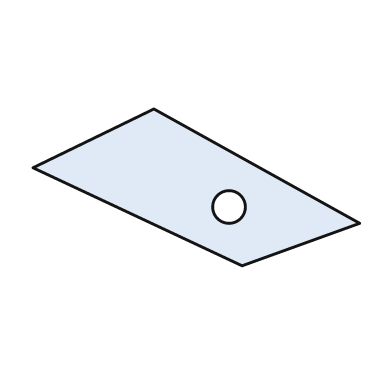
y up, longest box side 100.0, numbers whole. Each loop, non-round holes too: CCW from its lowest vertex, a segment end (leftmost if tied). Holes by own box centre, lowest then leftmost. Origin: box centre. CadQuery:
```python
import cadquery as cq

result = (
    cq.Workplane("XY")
    .moveTo(14.0, -24.0)
    .lineTo(50.0, -11.0)
    .lineTo(-13.0, 24.0)
    .lineTo(-50.0, 6.0)
    .close()
    .moveTo(10.0, -6.0)
    .circle(5.0)
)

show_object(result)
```